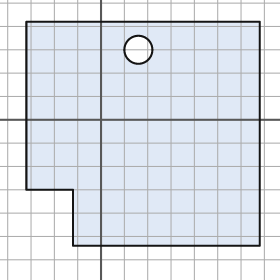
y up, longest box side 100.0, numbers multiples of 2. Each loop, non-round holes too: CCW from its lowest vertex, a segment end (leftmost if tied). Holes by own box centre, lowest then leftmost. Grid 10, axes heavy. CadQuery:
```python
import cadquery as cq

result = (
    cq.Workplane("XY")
    .moveTo(-12.0, -54.0)
    .lineTo(68.0, -54.0)
    .lineTo(68.0, 42.0)
    .lineTo(-32.0, 42.0)
    .lineTo(-32.0, -30.0)
    .lineTo(-12.0, -30.0)
    .close()
    .moveTo(16.0, 30.0)
    .circle(6.0)
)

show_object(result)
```